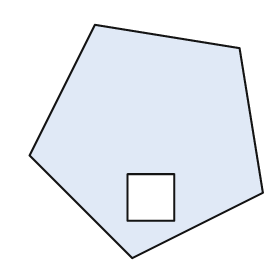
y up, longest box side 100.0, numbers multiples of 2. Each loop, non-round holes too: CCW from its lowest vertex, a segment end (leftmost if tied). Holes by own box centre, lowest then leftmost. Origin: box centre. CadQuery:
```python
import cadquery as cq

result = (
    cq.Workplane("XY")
    .moveTo(-6.0, -50.0)
    .lineTo(50.0, -22.0)
    .lineTo(40.0, 40.0)
    .lineTo(-22.0, 50.0)
    .lineTo(-50.0, -6.0)
    .close()
    .moveTo(-8.0, -34.0)
    .lineTo(12.0, -34.0)
    .lineTo(12.0, -14.0)
    .lineTo(-8.0, -14.0)
    .close()
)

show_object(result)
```